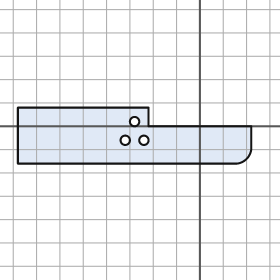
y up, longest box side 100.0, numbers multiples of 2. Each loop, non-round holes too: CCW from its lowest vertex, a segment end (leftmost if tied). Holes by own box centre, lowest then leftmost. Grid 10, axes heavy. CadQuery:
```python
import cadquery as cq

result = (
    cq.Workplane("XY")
    .moveTo(-78.0, -16.0)
    .lineTo(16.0, -16.0)
    .threePointArc((20.0, -14.0), (22.0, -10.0))
    .lineTo(22.0, 0.0)
    .lineTo(-22.0, 0.0)
    .lineTo(-22.0, 8.0)
    .lineTo(-78.0, 8.0)
    .close()
    .moveTo(-32.0, -6.0)
    .circle(2.0)
    .moveTo(-24.0, -6.0)
    .circle(2.0)
    .moveTo(-28.0, 2.0)
    .circle(2.0)
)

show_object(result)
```